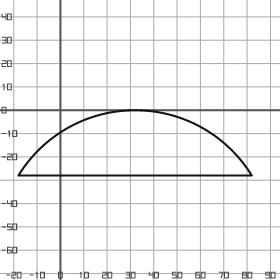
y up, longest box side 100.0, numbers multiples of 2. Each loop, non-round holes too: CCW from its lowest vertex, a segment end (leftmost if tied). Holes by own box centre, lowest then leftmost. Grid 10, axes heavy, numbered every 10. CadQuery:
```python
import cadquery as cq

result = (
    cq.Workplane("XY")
    .moveTo(-18.0, -28.0)
    .lineTo(82.0, -28.0)
    .threePointArc((32.0, 0.0), (-18.0, -28.0))
    .close()
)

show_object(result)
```